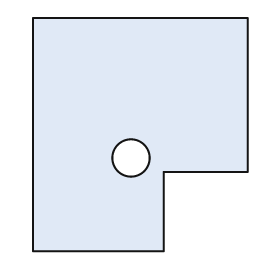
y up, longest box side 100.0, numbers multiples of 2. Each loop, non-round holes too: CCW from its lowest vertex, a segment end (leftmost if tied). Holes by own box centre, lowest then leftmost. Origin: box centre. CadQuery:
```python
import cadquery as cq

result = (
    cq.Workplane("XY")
    .moveTo(-46.0, -50.0)
    .lineTo(10.0, -50.0)
    .lineTo(10.0, -16.0)
    .lineTo(46.0, -16.0)
    .lineTo(46.0, 50.0)
    .lineTo(-46.0, 50.0)
    .close()
    .moveTo(-4.0, -10.0)
    .circle(8.0)
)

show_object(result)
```